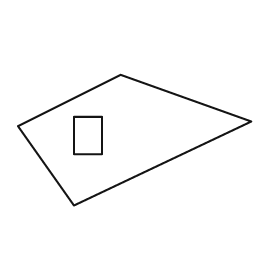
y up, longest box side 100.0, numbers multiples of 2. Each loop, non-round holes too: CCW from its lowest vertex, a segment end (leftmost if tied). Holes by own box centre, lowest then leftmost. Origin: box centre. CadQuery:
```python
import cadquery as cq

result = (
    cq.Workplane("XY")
    .moveTo(-26.0, -28.0)
    .lineTo(50.0, 8.0)
    .lineTo(-6.0, 28.0)
    .lineTo(-50.0, 6.0)
    .close()
    .moveTo(-26.0, -6.0)
    .lineTo(-14.0, -6.0)
    .lineTo(-14.0, 10.0)
    .lineTo(-26.0, 10.0)
    .close()
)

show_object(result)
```